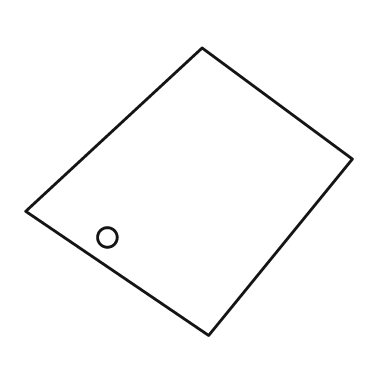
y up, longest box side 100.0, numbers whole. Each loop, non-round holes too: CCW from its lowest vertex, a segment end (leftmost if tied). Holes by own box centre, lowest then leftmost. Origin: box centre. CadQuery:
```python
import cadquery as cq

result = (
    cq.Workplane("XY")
    .moveTo(6.0, -44.0)
    .lineTo(50.0, 10.0)
    .lineTo(4.0, 44.0)
    .lineTo(-50.0, -6.0)
    .close()
    .moveTo(-25.0, -14.0)
    .circle(3.0)
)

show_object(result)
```